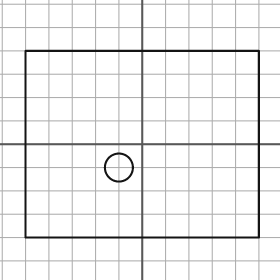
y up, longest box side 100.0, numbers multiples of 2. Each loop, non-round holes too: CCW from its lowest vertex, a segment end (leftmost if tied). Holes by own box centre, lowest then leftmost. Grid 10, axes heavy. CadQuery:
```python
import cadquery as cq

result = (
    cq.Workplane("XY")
    .moveTo(-50.0, -40.0)
    .lineTo(50.0, -40.0)
    .lineTo(50.0, 40.0)
    .lineTo(-50.0, 40.0)
    .close()
    .moveTo(-10.0, -10.0)
    .circle(6.0)
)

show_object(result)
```